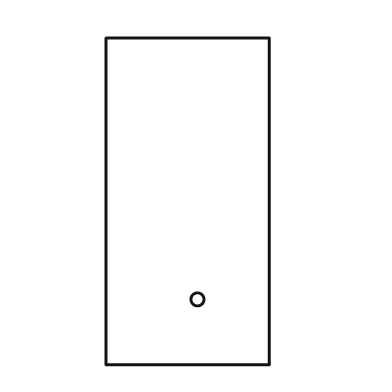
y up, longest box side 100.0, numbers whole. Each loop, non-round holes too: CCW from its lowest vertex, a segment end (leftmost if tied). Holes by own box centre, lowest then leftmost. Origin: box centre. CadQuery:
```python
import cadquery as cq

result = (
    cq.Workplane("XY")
    .moveTo(-25.0, -50.0)
    .lineTo(25.0, -50.0)
    .lineTo(25.0, 50.0)
    .lineTo(-25.0, 50.0)
    .close()
    .moveTo(3.0, -30.0)
    .circle(2.0)
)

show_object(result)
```